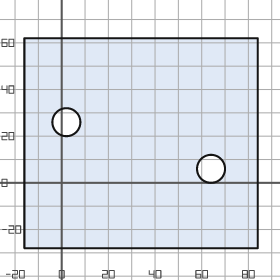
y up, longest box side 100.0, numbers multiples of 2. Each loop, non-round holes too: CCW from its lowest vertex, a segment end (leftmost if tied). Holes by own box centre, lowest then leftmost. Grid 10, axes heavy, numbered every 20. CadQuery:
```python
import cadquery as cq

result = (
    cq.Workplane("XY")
    .moveTo(-16.0, -28.0)
    .lineTo(84.0, -28.0)
    .lineTo(84.0, 62.0)
    .lineTo(-16.0, 62.0)
    .close()
    .moveTo(64.0, 6.0)
    .circle(6.0)
    .moveTo(2.0, 26.0)
    .circle(6.0)
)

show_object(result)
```